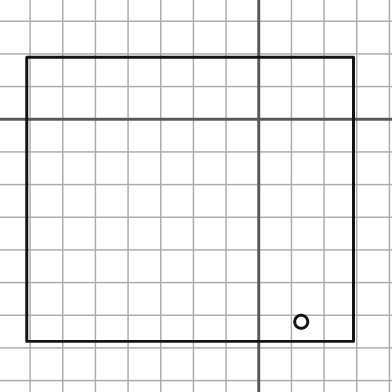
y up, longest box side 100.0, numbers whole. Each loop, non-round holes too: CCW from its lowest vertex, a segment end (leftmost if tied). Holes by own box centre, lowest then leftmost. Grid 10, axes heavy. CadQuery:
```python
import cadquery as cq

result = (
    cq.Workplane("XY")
    .moveTo(-71.0, -68.0)
    .lineTo(29.0, -68.0)
    .lineTo(29.0, 19.0)
    .lineTo(-71.0, 19.0)
    .close()
    .moveTo(13.0, -62.0)
    .circle(2.0)
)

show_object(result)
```